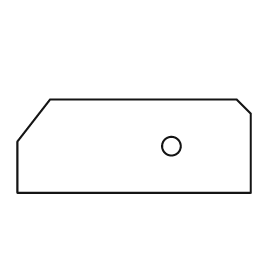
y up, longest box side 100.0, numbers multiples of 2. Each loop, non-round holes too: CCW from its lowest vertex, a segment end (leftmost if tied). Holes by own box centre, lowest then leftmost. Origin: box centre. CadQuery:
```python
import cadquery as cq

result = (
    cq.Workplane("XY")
    .moveTo(-50.0, -20.0)
    .lineTo(50.0, -20.0)
    .lineTo(50.0, 14.0)
    .lineTo(44.0, 20.0)
    .lineTo(-36.0, 20.0)
    .lineTo(-50.0, 2.0)
    .close()
    .moveTo(16.0, 0.0)
    .circle(4.0)
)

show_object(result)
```